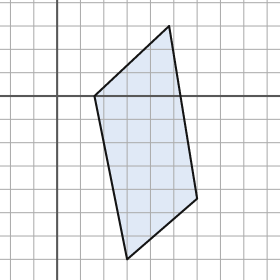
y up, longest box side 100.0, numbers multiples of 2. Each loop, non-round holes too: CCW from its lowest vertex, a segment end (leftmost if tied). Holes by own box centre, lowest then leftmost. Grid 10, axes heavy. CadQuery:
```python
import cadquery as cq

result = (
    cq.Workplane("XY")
    .moveTo(30.0, -70.0)
    .lineTo(60.0, -44.0)
    .lineTo(48.0, 30.0)
    .lineTo(16.0, 0.0)
    .close()
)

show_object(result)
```